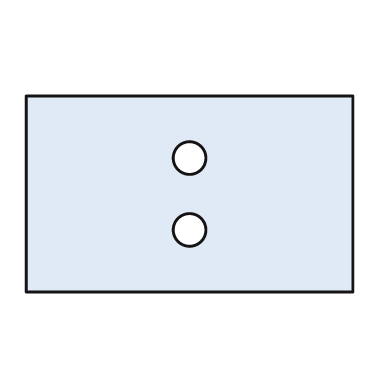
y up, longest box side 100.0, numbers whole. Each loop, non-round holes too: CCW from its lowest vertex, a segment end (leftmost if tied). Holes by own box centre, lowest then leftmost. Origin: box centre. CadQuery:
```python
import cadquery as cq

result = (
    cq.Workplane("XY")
    .moveTo(-50.0, -30.0)
    .lineTo(50.0, -30.0)
    .lineTo(50.0, 30.0)
    .lineTo(-50.0, 30.0)
    .close()
    .moveTo(0.0, -11.0)
    .circle(5.0)
    .moveTo(0.0, 11.0)
    .circle(5.0)
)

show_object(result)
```